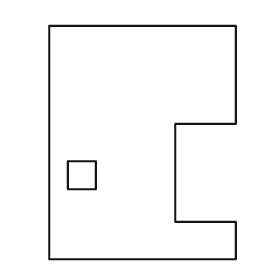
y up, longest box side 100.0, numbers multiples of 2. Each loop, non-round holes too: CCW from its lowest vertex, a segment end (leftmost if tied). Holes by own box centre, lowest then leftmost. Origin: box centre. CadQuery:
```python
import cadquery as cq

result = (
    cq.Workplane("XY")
    .moveTo(-40.0, -50.0)
    .lineTo(40.0, -50.0)
    .lineTo(40.0, -34.0)
    .lineTo(14.0, -34.0)
    .lineTo(14.0, 8.0)
    .lineTo(40.0, 8.0)
    .lineTo(40.0, 50.0)
    .lineTo(-40.0, 50.0)
    .close()
    .moveTo(-32.0, -20.0)
    .lineTo(-20.0, -20.0)
    .lineTo(-20.0, -8.0)
    .lineTo(-32.0, -8.0)
    .close()
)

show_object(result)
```